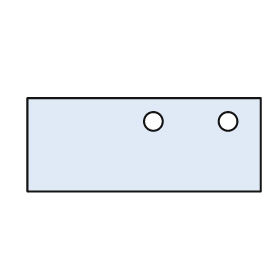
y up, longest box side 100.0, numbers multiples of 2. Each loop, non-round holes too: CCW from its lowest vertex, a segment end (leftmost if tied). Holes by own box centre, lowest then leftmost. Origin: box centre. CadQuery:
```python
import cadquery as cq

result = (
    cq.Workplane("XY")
    .moveTo(-50.0, -20.0)
    .lineTo(50.0, -20.0)
    .lineTo(50.0, 20.0)
    .lineTo(-50.0, 20.0)
    .close()
    .moveTo(4.0, 10.0)
    .circle(4.0)
    .moveTo(36.0, 10.0)
    .circle(4.0)
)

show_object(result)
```